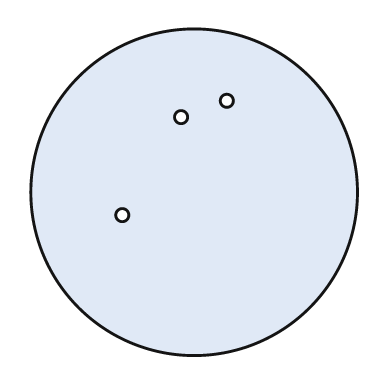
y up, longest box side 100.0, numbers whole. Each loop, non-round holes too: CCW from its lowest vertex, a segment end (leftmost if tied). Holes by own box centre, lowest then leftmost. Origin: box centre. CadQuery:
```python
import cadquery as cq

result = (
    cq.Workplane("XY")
    .moveTo(0.0, 0.0)
    .circle(50.0)
    .moveTo(-22.0, -7.0)
    .circle(2.0)
    .moveTo(-4.0, 23.0)
    .circle(2.0)
    .moveTo(10.0, 28.0)
    .circle(2.0)
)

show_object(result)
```